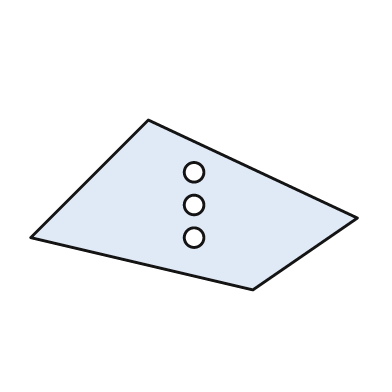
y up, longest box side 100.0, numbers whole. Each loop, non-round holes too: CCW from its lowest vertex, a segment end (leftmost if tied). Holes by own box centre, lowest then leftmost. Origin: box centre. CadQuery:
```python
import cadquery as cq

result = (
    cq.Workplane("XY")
    .moveTo(18.0, -26.0)
    .lineTo(50.0, -4.0)
    .lineTo(-14.0, 26.0)
    .lineTo(-50.0, -10.0)
    .close()
    .moveTo(0.0, -10.0)
    .circle(3.0)
    .moveTo(0.0, 0.0)
    .circle(3.0)
    .moveTo(0.0, 10.0)
    .circle(3.0)
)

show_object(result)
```